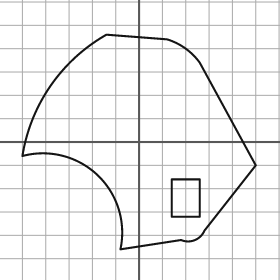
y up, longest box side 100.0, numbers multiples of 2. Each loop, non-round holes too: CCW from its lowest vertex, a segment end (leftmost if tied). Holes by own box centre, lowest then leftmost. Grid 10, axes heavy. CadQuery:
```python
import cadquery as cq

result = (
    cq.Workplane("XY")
    .moveTo(-8.0, -46.0)
    .lineTo(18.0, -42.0)
    .threePointArc((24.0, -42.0), (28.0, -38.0))
    .lineTo(50.0, -10.0)
    .lineTo(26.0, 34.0)
    .threePointArc((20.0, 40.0), (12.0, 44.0))
    .lineTo(-14.0, 46.0)
    .threePointArc((-38.0, 24.0), (-50.0, -6.0))
    .threePointArc((-18.0, -14.0), (-8.0, -46.0))
    .close()
    .moveTo(14.0, -32.0)
    .lineTo(26.0, -32.0)
    .lineTo(26.0, -16.0)
    .lineTo(14.0, -16.0)
    .close()
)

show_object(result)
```